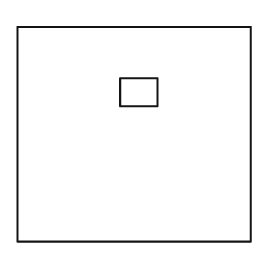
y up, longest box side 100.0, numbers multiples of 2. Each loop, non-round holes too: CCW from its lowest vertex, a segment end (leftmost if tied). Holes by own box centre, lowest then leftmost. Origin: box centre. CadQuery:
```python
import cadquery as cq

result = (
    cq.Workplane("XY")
    .moveTo(-50.0, -46.0)
    .lineTo(50.0, -46.0)
    .lineTo(50.0, 46.0)
    .lineTo(-50.0, 46.0)
    .close()
    .moveTo(-6.0, 12.0)
    .lineTo(10.0, 12.0)
    .lineTo(10.0, 24.0)
    .lineTo(-6.0, 24.0)
    .close()
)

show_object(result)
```